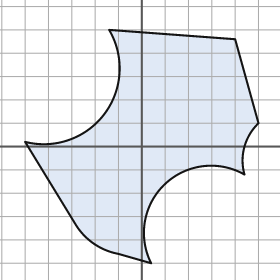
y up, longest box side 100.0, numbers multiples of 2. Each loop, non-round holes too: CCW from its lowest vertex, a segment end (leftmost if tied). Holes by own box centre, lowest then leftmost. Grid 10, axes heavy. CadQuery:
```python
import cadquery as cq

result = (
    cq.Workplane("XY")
    .moveTo(4.0, -50.0)
    .threePointArc((10.0, -16.0), (44.0, -12.0))
    .threePointArc((44.0, 0.0), (50.0, 10.0))
    .lineTo(40.0, 46.0)
    .lineTo(-14.0, 50.0)
    .threePointArc((-16.0, 14.0), (-50.0, 2.0))
    .lineTo(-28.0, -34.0)
    .threePointArc((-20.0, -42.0), (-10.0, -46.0))
    .close()
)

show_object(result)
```